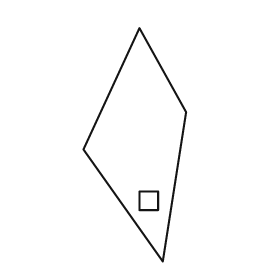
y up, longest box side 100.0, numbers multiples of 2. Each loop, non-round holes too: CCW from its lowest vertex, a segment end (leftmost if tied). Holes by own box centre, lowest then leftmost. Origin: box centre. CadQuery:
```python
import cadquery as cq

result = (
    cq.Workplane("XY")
    .moveTo(12.0, -50.0)
    .lineTo(22.0, 14.0)
    .lineTo(2.0, 50.0)
    .lineTo(-22.0, -2.0)
    .close()
    .moveTo(2.0, -28.0)
    .lineTo(10.0, -28.0)
    .lineTo(10.0, -20.0)
    .lineTo(2.0, -20.0)
    .close()
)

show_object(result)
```